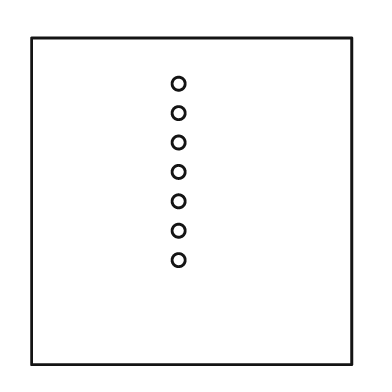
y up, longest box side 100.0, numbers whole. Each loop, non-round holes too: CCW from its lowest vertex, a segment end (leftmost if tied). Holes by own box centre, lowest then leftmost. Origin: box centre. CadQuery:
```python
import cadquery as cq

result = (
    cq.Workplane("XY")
    .moveTo(-49.0, -50.0)
    .lineTo(49.0, -50.0)
    .lineTo(49.0, 50.0)
    .lineTo(-49.0, 50.0)
    .close()
    .moveTo(-4.0, -18.0)
    .circle(2.0)
    .moveTo(-4.0, -9.0)
    .circle(2.0)
    .moveTo(-4.0, 0.0)
    .circle(2.0)
    .moveTo(-4.0, 9.0)
    .circle(2.0)
    .moveTo(-4.0, 18.0)
    .circle(2.0)
    .moveTo(-4.0, 27.0)
    .circle(2.0)
    .moveTo(-4.0, 36.0)
    .circle(2.0)
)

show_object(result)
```